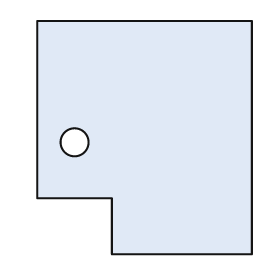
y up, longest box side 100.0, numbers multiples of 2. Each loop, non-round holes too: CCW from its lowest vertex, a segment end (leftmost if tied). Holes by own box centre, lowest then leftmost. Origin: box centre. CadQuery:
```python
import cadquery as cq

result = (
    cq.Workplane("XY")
    .moveTo(-14.0, -50.0)
    .lineTo(46.0, -50.0)
    .lineTo(46.0, 50.0)
    .lineTo(-46.0, 50.0)
    .lineTo(-46.0, -26.0)
    .lineTo(-14.0, -26.0)
    .close()
    .moveTo(-30.0, -2.0)
    .circle(6.0)
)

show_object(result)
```